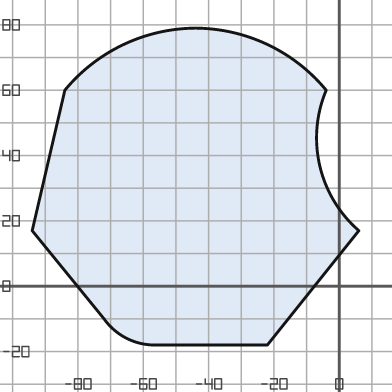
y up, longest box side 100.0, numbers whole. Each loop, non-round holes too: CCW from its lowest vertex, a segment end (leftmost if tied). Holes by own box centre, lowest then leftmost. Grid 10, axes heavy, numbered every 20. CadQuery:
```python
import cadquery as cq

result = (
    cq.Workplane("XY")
    .moveTo(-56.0, -18.0)
    .lineTo(-22.0, -18.0)
    .lineTo(6.0, 17.0)
    .threePointArc((-6.0, 37.0), (-4.0, 60.0))
    .threePointArc((-22.0, 74.0), (-44.0, 79.0))
    .threePointArc((-66.0, 74.0), (-84.0, 60.0))
    .lineTo(-94.0, 17.0)
    .lineTo(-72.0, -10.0)
    .threePointArc((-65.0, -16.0), (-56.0, -18.0))
    .close()
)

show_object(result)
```